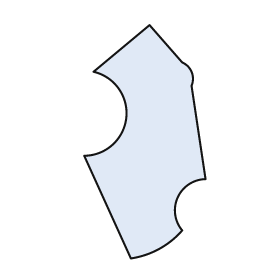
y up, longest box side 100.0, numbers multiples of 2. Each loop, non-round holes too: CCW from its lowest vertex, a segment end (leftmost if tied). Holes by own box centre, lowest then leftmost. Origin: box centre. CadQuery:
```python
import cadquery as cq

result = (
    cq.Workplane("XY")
    .moveTo(-6.0, -50.0)
    .threePointArc((6.0, -46.0), (16.0, -38.0))
    .threePointArc((14.0, -24.0), (26.0, -16.0))
    .lineTo(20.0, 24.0)
    .threePointArc((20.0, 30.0), (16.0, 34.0))
    .lineTo(2.0, 50.0)
    .lineTo(-22.0, 30.0)
    .threePointArc((-8.0, 10.0), (-26.0, -6.0))
    .close()
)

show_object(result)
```